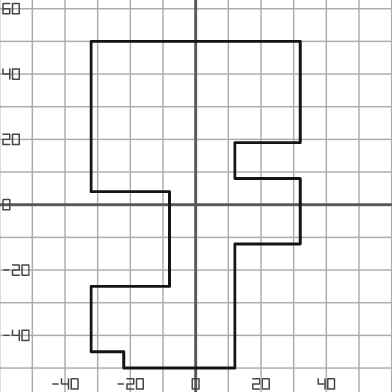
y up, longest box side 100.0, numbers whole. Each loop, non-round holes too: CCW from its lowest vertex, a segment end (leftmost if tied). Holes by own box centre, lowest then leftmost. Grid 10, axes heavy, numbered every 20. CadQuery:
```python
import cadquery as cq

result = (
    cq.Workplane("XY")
    .moveTo(-22.0, -50.0)
    .lineTo(12.0, -50.0)
    .lineTo(12.0, -12.0)
    .lineTo(32.0, -12.0)
    .lineTo(32.0, 8.0)
    .lineTo(12.0, 8.0)
    .lineTo(12.0, 19.0)
    .lineTo(32.0, 19.0)
    .lineTo(32.0, 50.0)
    .lineTo(-32.0, 50.0)
    .lineTo(-32.0, 4.0)
    .lineTo(-8.0, 4.0)
    .lineTo(-8.0, -25.0)
    .lineTo(-32.0, -25.0)
    .lineTo(-32.0, -45.0)
    .lineTo(-22.0, -45.0)
    .close()
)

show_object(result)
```